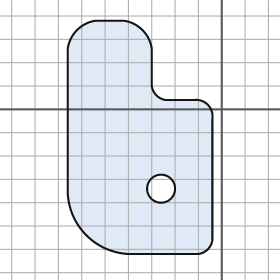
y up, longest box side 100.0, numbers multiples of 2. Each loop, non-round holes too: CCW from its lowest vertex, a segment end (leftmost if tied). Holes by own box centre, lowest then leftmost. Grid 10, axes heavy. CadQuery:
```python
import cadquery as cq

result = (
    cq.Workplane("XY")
    .moveTo(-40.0, -62.0)
    .lineTo(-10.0, -62.0)
    .threePointArc((-6.0, -60.0), (-4.0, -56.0))
    .lineTo(-4.0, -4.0)
    .threePointArc((-6.0, 2.0), (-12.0, 4.0))
    .lineTo(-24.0, 4.0)
    .threePointArc((-28.0, 6.0), (-30.0, 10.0))
    .lineTo(-30.0, 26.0)
    .threePointArc((-34.0, 34.0), (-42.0, 38.0))
    .lineTo(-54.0, 38.0)
    .threePointArc((-62.0, 34.0), (-66.0, 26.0))
    .lineTo(-66.0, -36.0)
    .threePointArc((-58.0, -54.0), (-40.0, -62.0))
    .close()
    .moveTo(-26.0, -34.0)
    .circle(6.0)
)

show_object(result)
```